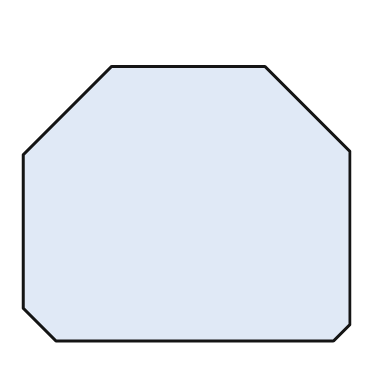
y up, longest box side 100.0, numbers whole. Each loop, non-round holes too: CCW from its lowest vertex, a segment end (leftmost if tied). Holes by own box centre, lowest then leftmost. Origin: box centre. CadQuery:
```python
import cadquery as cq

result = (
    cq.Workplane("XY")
    .moveTo(-40.0, -42.0)
    .lineTo(45.0, -42.0)
    .lineTo(50.0, -37.0)
    .lineTo(50.0, 16.0)
    .lineTo(24.0, 42.0)
    .lineTo(-23.0, 42.0)
    .lineTo(-50.0, 15.0)
    .lineTo(-50.0, -32.0)
    .close()
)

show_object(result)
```